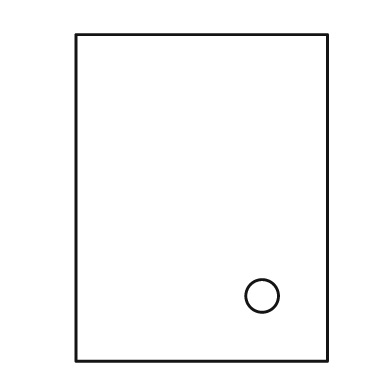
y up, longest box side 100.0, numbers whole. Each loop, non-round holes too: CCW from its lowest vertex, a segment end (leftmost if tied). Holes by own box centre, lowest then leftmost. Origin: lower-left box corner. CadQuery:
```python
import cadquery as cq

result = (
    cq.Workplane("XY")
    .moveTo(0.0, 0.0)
    .lineTo(77.0, 0.0)
    .lineTo(77.0, 100.0)
    .lineTo(0.0, 100.0)
    .close()
    .moveTo(57.0, 20.0)
    .circle(5.0)
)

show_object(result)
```